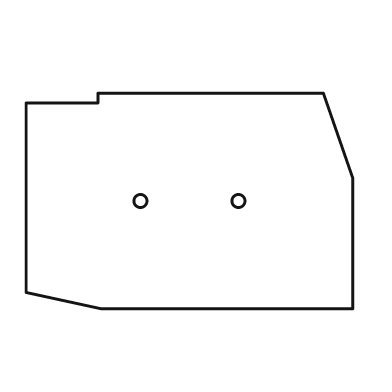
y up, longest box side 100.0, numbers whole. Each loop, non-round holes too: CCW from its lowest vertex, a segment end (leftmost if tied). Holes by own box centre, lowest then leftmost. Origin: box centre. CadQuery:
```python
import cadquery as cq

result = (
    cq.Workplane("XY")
    .moveTo(-27.0, -33.0)
    .lineTo(50.0, -33.0)
    .lineTo(50.0, 7.0)
    .lineTo(41.0, 33.0)
    .lineTo(-28.0, 33.0)
    .lineTo(-28.0, 30.0)
    .lineTo(-50.0, 30.0)
    .lineTo(-50.0, -28.0)
    .close()
    .moveTo(-15.0, 0.0)
    .circle(2.0)
    .moveTo(15.0, 0.0)
    .circle(2.0)
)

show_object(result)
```